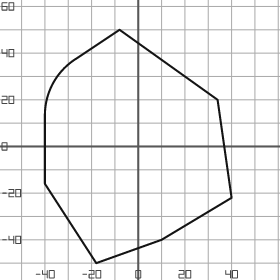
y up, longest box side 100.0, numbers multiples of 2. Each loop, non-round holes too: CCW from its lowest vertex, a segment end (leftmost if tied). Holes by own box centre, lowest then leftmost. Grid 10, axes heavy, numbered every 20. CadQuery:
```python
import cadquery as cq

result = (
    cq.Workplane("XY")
    .moveTo(-18.0, -50.0)
    .lineTo(10.0, -40.0)
    .lineTo(40.0, -22.0)
    .lineTo(34.0, 20.0)
    .lineTo(-8.0, 50.0)
    .lineTo(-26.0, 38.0)
    .threePointArc((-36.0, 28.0), (-40.0, 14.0))
    .lineTo(-40.0, -16.0)
    .close()
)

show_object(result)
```